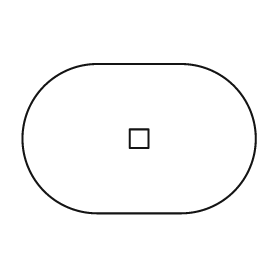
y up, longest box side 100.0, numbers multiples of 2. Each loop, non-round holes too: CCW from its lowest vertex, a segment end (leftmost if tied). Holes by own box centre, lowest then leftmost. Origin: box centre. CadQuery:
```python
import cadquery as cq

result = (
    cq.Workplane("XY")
    .moveTo(-18.0, -32.0)
    .lineTo(18.0, -32.0)
    .threePointArc((50.0, 0.0), (18.0, 32.0))
    .lineTo(-18.0, 32.0)
    .threePointArc((-50.0, 0.0), (-18.0, -32.0))
    .close()
    .moveTo(-4.0, -4.0)
    .lineTo(4.0, -4.0)
    .lineTo(4.0, 4.0)
    .lineTo(-4.0, 4.0)
    .close()
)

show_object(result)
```